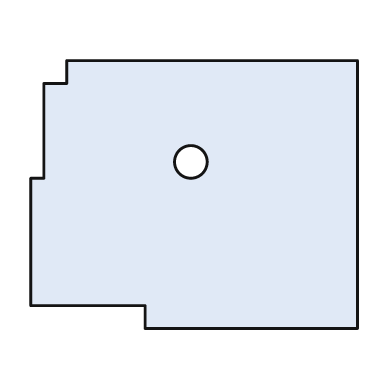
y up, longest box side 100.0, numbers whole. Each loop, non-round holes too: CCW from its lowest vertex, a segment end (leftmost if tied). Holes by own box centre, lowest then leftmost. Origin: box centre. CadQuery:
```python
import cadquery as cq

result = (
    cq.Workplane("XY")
    .moveTo(-15.0, -41.0)
    .lineTo(50.0, -41.0)
    .lineTo(50.0, 41.0)
    .lineTo(-39.0, 41.0)
    .lineTo(-39.0, 34.0)
    .lineTo(-46.0, 34.0)
    .lineTo(-46.0, 5.0)
    .lineTo(-50.0, 5.0)
    .lineTo(-50.0, -34.0)
    .lineTo(-15.0, -34.0)
    .close()
    .moveTo(-1.0, 10.0)
    .circle(5.0)
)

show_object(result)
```